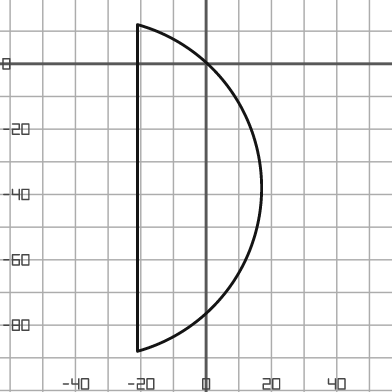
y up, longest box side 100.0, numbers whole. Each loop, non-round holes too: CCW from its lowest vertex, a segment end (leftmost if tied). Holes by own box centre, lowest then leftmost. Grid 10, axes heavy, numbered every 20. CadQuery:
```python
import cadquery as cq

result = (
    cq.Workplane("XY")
    .moveTo(-21.0, -88.0)
    .threePointArc((17.0, -38.0), (-21.0, 12.0))
    .close()
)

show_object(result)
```